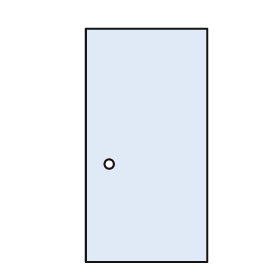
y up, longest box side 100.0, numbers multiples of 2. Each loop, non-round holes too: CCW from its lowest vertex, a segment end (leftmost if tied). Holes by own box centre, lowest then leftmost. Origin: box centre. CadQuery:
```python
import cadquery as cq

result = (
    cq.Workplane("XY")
    .moveTo(-26.0, -50.0)
    .lineTo(26.0, -50.0)
    .lineTo(26.0, 50.0)
    .lineTo(-26.0, 50.0)
    .close()
    .moveTo(-16.0, -8.0)
    .circle(2.0)
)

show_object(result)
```